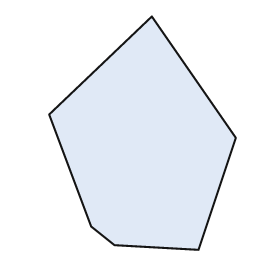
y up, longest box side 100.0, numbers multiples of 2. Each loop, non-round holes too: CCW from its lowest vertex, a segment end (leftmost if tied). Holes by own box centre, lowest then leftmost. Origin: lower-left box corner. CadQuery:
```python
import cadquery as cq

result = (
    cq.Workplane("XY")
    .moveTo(64.0, 0.0)
    .lineTo(80.0, 48.0)
    .lineTo(44.0, 100.0)
    .lineTo(0.0, 58.0)
    .lineTo(18.0, 10.0)
    .lineTo(28.0, 2.0)
    .close()
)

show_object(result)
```